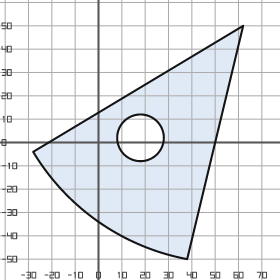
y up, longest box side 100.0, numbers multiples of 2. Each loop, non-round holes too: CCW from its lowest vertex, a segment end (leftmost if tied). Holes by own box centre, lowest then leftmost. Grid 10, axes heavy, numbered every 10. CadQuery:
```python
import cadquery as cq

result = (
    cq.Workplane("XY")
    .moveTo(38.0, -50.0)
    .lineTo(62.0, 50.0)
    .lineTo(-28.0, -4.0)
    .threePointArc((0.0, -34.0), (38.0, -50.0))
    .close()
    .moveTo(18.0, 2.0)
    .circle(10.0)
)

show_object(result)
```